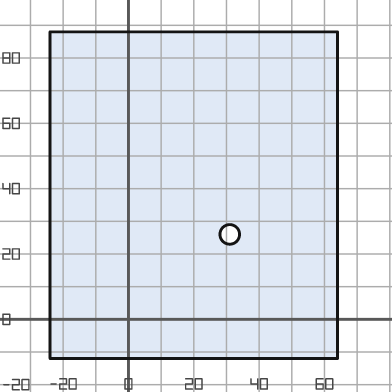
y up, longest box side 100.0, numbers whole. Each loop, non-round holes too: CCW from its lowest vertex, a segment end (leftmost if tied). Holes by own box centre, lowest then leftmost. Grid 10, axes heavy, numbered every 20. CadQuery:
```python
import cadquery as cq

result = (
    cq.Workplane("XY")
    .moveTo(-24.0, -12.0)
    .lineTo(64.0, -12.0)
    .lineTo(64.0, 88.0)
    .lineTo(-24.0, 88.0)
    .close()
    .moveTo(31.0, 26.0)
    .circle(3.0)
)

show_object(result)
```